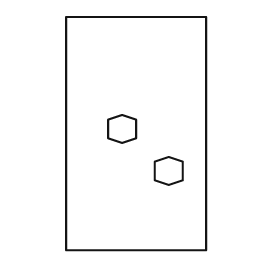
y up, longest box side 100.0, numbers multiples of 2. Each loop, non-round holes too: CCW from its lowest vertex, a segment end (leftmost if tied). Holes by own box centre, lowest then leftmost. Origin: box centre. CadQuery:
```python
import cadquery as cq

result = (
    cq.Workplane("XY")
    .moveTo(-30.0, -50.0)
    .lineTo(30.0, -50.0)
    .lineTo(30.0, 50.0)
    .lineTo(-30.0, 50.0)
    .close()
    .moveTo(14.0, -22.0)
    .lineTo(20.0, -20.0)
    .lineTo(20.0, -12.0)
    .lineTo(14.0, -10.0)
    .lineTo(8.0, -12.0)
    .lineTo(8.0, -20.0)
    .close()
    .moveTo(-6.0, -4.0)
    .lineTo(0.0, -2.0)
    .lineTo(0.0, 6.0)
    .lineTo(-6.0, 8.0)
    .lineTo(-12.0, 6.0)
    .lineTo(-12.0, -2.0)
    .close()
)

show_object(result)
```